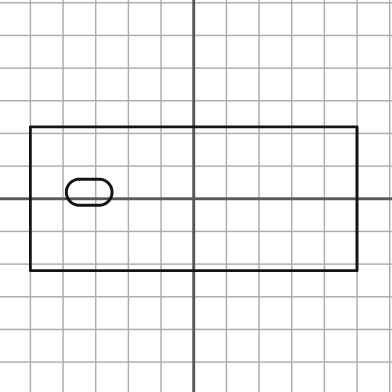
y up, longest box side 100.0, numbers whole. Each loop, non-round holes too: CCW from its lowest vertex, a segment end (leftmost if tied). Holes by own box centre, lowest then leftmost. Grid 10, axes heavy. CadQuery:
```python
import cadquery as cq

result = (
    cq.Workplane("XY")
    .moveTo(-50.0, -22.0)
    .lineTo(50.0, -22.0)
    .lineTo(50.0, 22.0)
    .lineTo(-50.0, 22.0)
    .close()
    .moveTo(-35.0, -2.0)
    .lineTo(-29.0, -2.0)
    .threePointArc((-25.0, 2.0), (-29.0, 6.0))
    .lineTo(-35.0, 6.0)
    .threePointArc((-39.0, 2.0), (-35.0, -2.0))
    .close()
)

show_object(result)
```